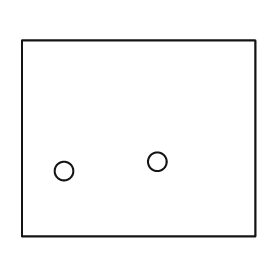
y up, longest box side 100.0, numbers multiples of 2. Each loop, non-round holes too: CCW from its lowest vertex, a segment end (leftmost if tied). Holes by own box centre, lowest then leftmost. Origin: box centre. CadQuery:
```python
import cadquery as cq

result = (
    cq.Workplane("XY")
    .moveTo(-50.0, -42.0)
    .lineTo(50.0, -42.0)
    .lineTo(50.0, 42.0)
    .lineTo(-50.0, 42.0)
    .close()
    .moveTo(-32.0, -14.0)
    .circle(4.0)
    .moveTo(8.0, -10.0)
    .circle(4.0)
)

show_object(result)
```